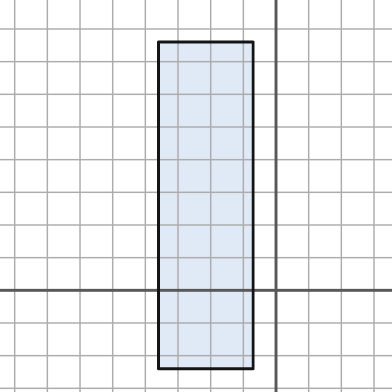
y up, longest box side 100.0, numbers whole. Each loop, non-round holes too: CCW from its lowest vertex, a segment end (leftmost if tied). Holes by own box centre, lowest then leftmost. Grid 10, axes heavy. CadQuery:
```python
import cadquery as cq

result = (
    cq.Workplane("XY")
    .moveTo(-36.0, -24.0)
    .lineTo(-7.0, -24.0)
    .lineTo(-7.0, 76.0)
    .lineTo(-36.0, 76.0)
    .close()
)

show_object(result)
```